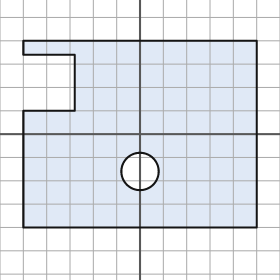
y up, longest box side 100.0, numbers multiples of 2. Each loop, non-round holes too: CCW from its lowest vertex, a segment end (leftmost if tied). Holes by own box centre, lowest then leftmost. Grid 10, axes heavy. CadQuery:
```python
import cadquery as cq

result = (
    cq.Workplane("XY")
    .moveTo(-50.0, -40.0)
    .lineTo(50.0, -40.0)
    .lineTo(50.0, 40.0)
    .lineTo(-50.0, 40.0)
    .lineTo(-50.0, 34.0)
    .lineTo(-28.0, 34.0)
    .lineTo(-28.0, 10.0)
    .lineTo(-50.0, 10.0)
    .close()
    .moveTo(0.0, -16.0)
    .circle(8.0)
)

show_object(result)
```